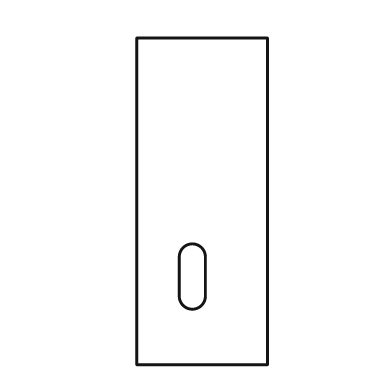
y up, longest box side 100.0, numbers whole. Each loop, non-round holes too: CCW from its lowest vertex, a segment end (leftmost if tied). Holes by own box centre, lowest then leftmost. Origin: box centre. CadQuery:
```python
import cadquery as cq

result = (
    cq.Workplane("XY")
    .moveTo(-20.0, -50.0)
    .lineTo(20.0, -50.0)
    .lineTo(20.0, 50.0)
    .lineTo(-20.0, 50.0)
    .close()
    .moveTo(-7.0, -29.0)
    .threePointArc((-3.0, -33.0), (1.0, -29.0))
    .lineTo(1.0, -17.0)
    .threePointArc((-3.0, -13.0), (-7.0, -17.0))
    .close()
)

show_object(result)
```